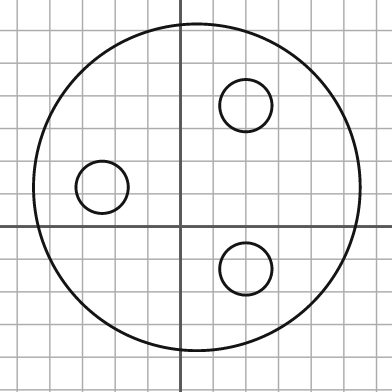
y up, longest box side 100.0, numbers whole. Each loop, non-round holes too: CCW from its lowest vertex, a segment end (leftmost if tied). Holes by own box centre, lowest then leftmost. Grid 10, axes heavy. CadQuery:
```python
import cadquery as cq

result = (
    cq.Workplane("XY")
    .moveTo(5.0, 12.0)
    .circle(50.0)
    .moveTo(20.0, -13.0)
    .circle(8.0)
    .moveTo(-24.0, 12.0)
    .circle(8.0)
    .moveTo(20.0, 37.0)
    .circle(8.0)
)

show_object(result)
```